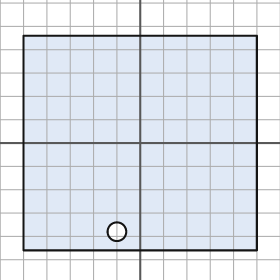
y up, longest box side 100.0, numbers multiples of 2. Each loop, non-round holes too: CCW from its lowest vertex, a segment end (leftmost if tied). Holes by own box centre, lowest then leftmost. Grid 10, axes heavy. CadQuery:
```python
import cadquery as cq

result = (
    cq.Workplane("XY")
    .moveTo(-50.0, -46.0)
    .lineTo(50.0, -46.0)
    .lineTo(50.0, 46.0)
    .lineTo(-50.0, 46.0)
    .close()
    .moveTo(-10.0, -38.0)
    .circle(4.0)
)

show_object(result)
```